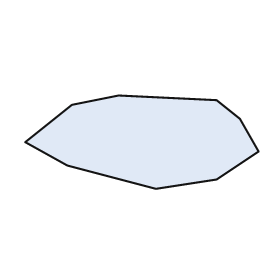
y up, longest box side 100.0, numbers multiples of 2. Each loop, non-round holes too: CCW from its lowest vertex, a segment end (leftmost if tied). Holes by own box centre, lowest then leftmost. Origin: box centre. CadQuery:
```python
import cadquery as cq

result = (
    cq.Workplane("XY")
    .moveTo(6.0, -20.0)
    .lineTo(32.0, -16.0)
    .lineTo(50.0, -4.0)
    .lineTo(42.0, 10.0)
    .lineTo(32.0, 18.0)
    .lineTo(-10.0, 20.0)
    .lineTo(-30.0, 16.0)
    .lineTo(-50.0, 0.0)
    .lineTo(-32.0, -10.0)
    .close()
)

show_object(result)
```